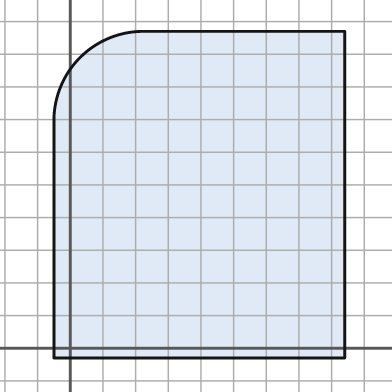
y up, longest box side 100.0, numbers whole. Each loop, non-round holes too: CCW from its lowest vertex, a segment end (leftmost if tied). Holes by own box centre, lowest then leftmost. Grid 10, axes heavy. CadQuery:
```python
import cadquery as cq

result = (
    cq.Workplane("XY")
    .moveTo(-5.0, -3.0)
    .lineTo(84.0, -3.0)
    .lineTo(84.0, 97.0)
    .lineTo(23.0, 97.0)
    .threePointArc((3.0, 89.0), (-5.0, 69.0))
    .close()
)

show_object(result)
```